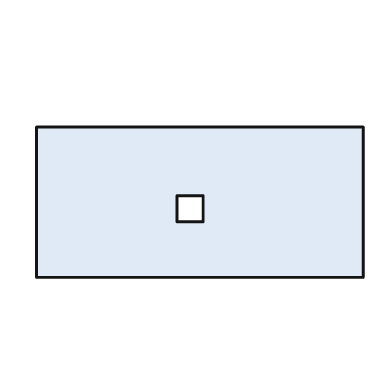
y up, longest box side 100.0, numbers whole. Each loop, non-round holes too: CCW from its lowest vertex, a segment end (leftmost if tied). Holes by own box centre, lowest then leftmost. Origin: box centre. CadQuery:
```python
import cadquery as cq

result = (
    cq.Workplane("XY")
    .moveTo(-50.0, -23.0)
    .lineTo(50.0, -23.0)
    .lineTo(50.0, 23.0)
    .lineTo(-50.0, 23.0)
    .close()
    .moveTo(-7.0, -6.0)
    .lineTo(1.0, -6.0)
    .lineTo(1.0, 2.0)
    .lineTo(-7.0, 2.0)
    .close()
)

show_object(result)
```